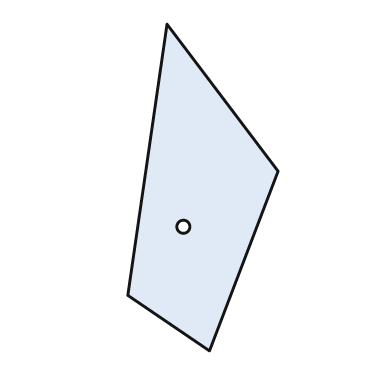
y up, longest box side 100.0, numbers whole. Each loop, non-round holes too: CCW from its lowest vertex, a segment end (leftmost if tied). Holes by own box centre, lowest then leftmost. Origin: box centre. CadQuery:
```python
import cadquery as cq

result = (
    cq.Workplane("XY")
    .moveTo(2.0, -50.0)
    .lineTo(23.0, 5.0)
    .lineTo(-11.0, 50.0)
    .lineTo(-23.0, -33.0)
    .close()
    .moveTo(-6.0, -12.0)
    .circle(2.0)
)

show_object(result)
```